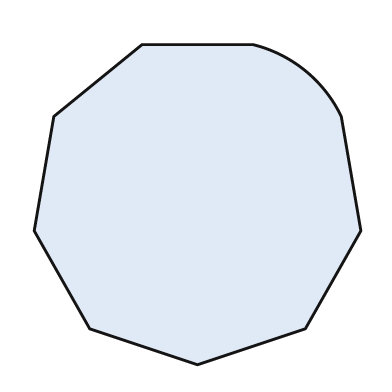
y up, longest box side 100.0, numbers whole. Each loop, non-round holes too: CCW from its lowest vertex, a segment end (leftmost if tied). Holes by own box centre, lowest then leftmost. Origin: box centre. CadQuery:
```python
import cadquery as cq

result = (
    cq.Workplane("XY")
    .moveTo(0.0, -49.0)
    .lineTo(33.0, -38.0)
    .lineTo(50.0, -8.0)
    .lineTo(44.0, 27.0)
    .threePointArc((33.0, 41.0), (17.0, 49.0))
    .lineTo(-17.0, 49.0)
    .lineTo(-44.0, 27.0)
    .lineTo(-50.0, -8.0)
    .lineTo(-33.0, -38.0)
    .close()
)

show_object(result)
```